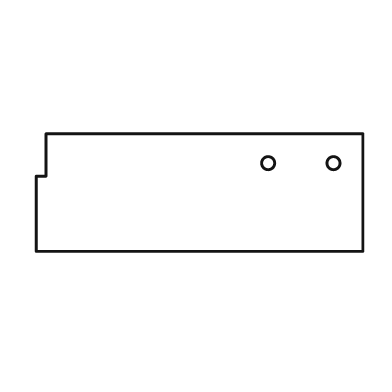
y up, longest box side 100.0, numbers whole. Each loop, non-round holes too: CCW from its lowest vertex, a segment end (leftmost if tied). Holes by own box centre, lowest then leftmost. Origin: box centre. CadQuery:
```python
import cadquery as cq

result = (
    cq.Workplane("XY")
    .moveTo(-50.0, -18.0)
    .lineTo(50.0, -18.0)
    .lineTo(50.0, 18.0)
    .lineTo(-47.0, 18.0)
    .lineTo(-47.0, 5.0)
    .lineTo(-50.0, 5.0)
    .close()
    .moveTo(21.0, 9.0)
    .circle(2.0)
    .moveTo(41.0, 9.0)
    .circle(2.0)
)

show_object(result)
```